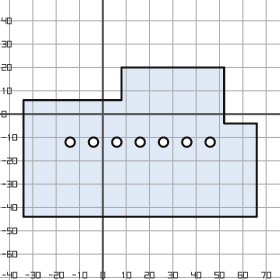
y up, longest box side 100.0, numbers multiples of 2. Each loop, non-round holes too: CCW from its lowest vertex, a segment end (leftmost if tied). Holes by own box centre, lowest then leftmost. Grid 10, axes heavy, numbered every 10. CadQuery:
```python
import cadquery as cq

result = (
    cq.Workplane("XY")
    .moveTo(-34.0, -44.0)
    .lineTo(66.0, -44.0)
    .lineTo(66.0, -4.0)
    .lineTo(52.0, -4.0)
    .lineTo(52.0, 20.0)
    .lineTo(8.0, 20.0)
    .lineTo(8.0, 6.0)
    .lineTo(-34.0, 6.0)
    .close()
    .moveTo(-14.0, -12.0)
    .circle(2.0)
    .moveTo(-4.0, -12.0)
    .circle(2.0)
    .moveTo(6.0, -12.0)
    .circle(2.0)
    .moveTo(16.0, -12.0)
    .circle(2.0)
    .moveTo(26.0, -12.0)
    .circle(2.0)
    .moveTo(36.0, -12.0)
    .circle(2.0)
    .moveTo(46.0, -12.0)
    .circle(2.0)
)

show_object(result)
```